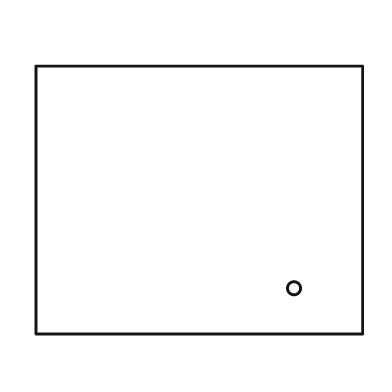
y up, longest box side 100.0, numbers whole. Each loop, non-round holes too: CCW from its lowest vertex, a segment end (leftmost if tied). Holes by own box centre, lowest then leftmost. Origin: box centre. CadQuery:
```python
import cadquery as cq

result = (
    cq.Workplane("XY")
    .moveTo(-50.0, -41.0)
    .lineTo(50.0, -41.0)
    .lineTo(50.0, 41.0)
    .lineTo(-50.0, 41.0)
    .close()
    .moveTo(29.0, -27.0)
    .circle(2.0)
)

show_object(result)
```